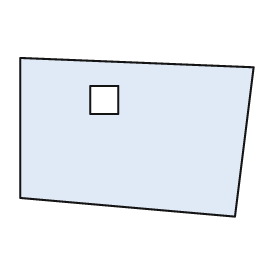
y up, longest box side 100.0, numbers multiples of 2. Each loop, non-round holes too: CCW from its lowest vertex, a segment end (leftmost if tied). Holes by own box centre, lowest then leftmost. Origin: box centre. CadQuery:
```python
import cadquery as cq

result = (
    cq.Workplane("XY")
    .moveTo(42.0, -34.0)
    .lineTo(50.0, 30.0)
    .lineTo(-50.0, 34.0)
    .lineTo(-50.0, -26.0)
    .close()
    .moveTo(-20.0, 10.0)
    .lineTo(-8.0, 10.0)
    .lineTo(-8.0, 22.0)
    .lineTo(-20.0, 22.0)
    .close()
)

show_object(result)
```